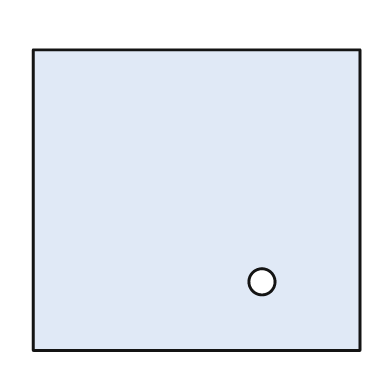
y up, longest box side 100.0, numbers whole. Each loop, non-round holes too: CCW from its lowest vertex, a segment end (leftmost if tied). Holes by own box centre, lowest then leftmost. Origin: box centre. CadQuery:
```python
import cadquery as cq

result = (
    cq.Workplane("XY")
    .moveTo(-50.0, -46.0)
    .lineTo(50.0, -46.0)
    .lineTo(50.0, 46.0)
    .lineTo(-50.0, 46.0)
    .close()
    .moveTo(20.0, -25.0)
    .circle(4.0)
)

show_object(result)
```